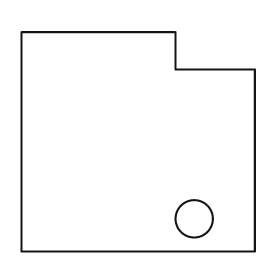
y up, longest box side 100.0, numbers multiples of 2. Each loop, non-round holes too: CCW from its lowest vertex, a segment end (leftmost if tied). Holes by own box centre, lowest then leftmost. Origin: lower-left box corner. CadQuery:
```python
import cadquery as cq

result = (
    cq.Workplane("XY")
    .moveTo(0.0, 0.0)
    .lineTo(100.0, 0.0)
    .lineTo(100.0, 78.0)
    .lineTo(66.0, 78.0)
    .lineTo(66.0, 94.0)
    .lineTo(0.0, 94.0)
    .close()
    .moveTo(74.0, 14.0)
    .circle(8.0)
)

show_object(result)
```